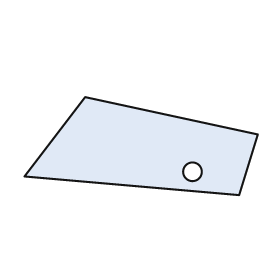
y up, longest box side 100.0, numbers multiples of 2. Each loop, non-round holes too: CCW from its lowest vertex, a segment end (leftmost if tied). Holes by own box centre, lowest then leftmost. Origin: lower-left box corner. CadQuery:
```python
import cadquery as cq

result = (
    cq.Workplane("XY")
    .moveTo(92.0, 0.0)
    .lineTo(100.0, 26.0)
    .lineTo(26.0, 42.0)
    .lineTo(0.0, 8.0)
    .close()
    .moveTo(72.0, 10.0)
    .circle(4.0)
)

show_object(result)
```